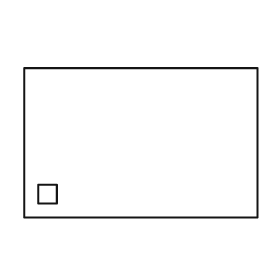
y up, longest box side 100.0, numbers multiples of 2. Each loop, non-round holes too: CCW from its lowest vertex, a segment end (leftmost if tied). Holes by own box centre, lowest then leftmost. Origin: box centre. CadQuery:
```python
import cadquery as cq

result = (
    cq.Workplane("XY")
    .moveTo(-50.0, -32.0)
    .lineTo(50.0, -32.0)
    .lineTo(50.0, 32.0)
    .lineTo(-50.0, 32.0)
    .close()
    .moveTo(-44.0, -26.0)
    .lineTo(-36.0, -26.0)
    .lineTo(-36.0, -18.0)
    .lineTo(-44.0, -18.0)
    .close()
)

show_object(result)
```